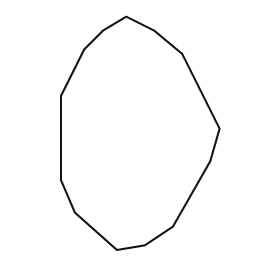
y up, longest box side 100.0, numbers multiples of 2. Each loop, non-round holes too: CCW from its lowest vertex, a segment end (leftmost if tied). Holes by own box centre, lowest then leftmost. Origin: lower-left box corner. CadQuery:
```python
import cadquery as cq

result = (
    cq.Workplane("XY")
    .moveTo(24.0, 0.0)
    .lineTo(36.0, 2.0)
    .lineTo(48.0, 10.0)
    .lineTo(64.0, 38.0)
    .lineTo(68.0, 52.0)
    .lineTo(52.0, 84.0)
    .lineTo(40.0, 94.0)
    .lineTo(28.0, 100.0)
    .lineTo(18.0, 94.0)
    .lineTo(10.0, 86.0)
    .lineTo(0.0, 66.0)
    .lineTo(0.0, 30.0)
    .lineTo(6.0, 16.0)
    .close()
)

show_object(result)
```